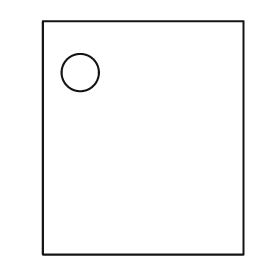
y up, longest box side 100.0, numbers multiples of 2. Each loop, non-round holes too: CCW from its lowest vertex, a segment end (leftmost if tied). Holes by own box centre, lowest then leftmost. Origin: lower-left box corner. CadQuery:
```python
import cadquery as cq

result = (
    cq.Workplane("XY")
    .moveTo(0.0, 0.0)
    .lineTo(86.0, 0.0)
    .lineTo(86.0, 100.0)
    .lineTo(0.0, 100.0)
    .close()
    .moveTo(16.0, 78.0)
    .circle(8.0)
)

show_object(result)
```